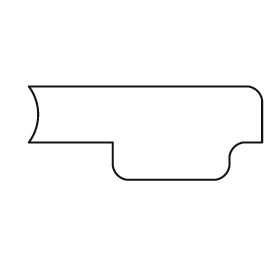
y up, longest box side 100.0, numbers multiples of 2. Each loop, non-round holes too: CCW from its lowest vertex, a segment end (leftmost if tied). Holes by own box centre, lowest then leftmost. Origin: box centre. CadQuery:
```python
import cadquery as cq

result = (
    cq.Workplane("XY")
    .moveTo(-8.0, -20.0)
    .lineTo(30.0, -20.0)
    .threePointArc((34.0, -18.0), (36.0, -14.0))
    .lineTo(36.0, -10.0)
    .threePointArc((38.0, -6.0), (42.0, -4.0))
    .lineTo(50.0, -4.0)
    .lineTo(50.0, 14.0)
    .threePointArc((48.0, 18.0), (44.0, 20.0))
    .lineTo(-50.0, 20.0)
    .threePointArc((-46.0, 8.0), (-50.0, -4.0))
    .lineTo(-14.0, -4.0)
    .lineTo(-14.0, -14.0)
    .threePointArc((-12.0, -18.0), (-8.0, -20.0))
    .close()
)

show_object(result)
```